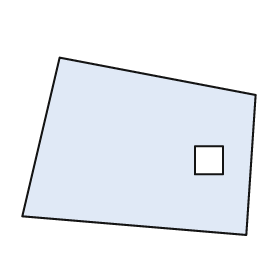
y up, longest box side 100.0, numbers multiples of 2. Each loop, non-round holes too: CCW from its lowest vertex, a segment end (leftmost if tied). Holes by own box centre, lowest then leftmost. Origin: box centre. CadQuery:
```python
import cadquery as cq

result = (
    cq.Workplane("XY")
    .moveTo(46.0, -38.0)
    .lineTo(50.0, 22.0)
    .lineTo(-34.0, 38.0)
    .lineTo(-50.0, -30.0)
    .close()
    .moveTo(24.0, -12.0)
    .lineTo(36.0, -12.0)
    .lineTo(36.0, 0.0)
    .lineTo(24.0, 0.0)
    .close()
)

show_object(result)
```